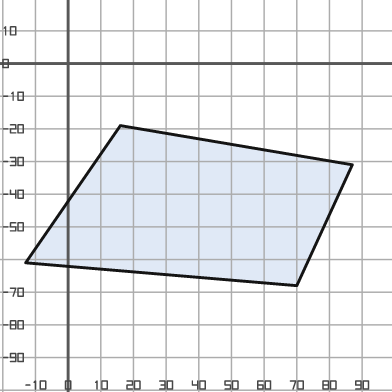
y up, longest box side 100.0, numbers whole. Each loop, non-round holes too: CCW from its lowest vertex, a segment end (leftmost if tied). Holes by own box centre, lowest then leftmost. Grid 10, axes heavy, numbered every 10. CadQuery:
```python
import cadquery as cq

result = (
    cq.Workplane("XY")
    .moveTo(70.0, -68.0)
    .lineTo(87.0, -31.0)
    .lineTo(16.0, -19.0)
    .lineTo(-13.0, -61.0)
    .close()
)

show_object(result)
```